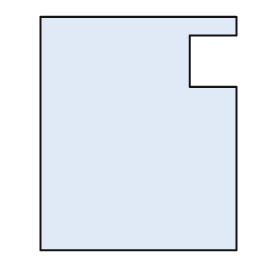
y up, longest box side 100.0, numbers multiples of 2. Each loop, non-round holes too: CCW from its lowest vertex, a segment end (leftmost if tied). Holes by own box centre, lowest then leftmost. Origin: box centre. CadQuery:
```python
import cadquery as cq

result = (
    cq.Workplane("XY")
    .moveTo(-42.0, -50.0)
    .lineTo(42.0, -50.0)
    .lineTo(42.0, 20.0)
    .lineTo(22.0, 20.0)
    .lineTo(22.0, 42.0)
    .lineTo(42.0, 42.0)
    .lineTo(42.0, 50.0)
    .lineTo(-42.0, 50.0)
    .close()
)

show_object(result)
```